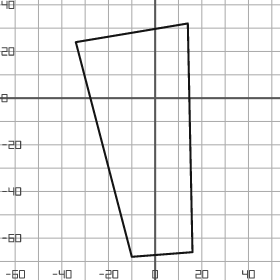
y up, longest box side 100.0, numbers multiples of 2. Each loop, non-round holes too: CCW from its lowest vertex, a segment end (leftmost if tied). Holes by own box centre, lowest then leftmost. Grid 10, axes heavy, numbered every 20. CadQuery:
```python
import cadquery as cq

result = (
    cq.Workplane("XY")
    .moveTo(-10.0, -68.0)
    .lineTo(16.0, -66.0)
    .lineTo(14.0, 32.0)
    .lineTo(-34.0, 24.0)
    .close()
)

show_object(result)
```